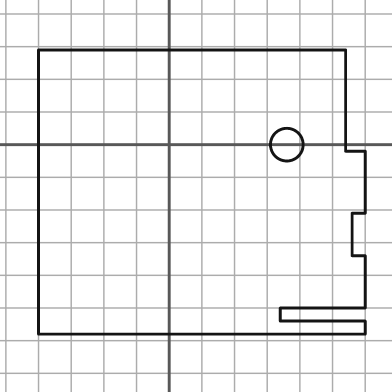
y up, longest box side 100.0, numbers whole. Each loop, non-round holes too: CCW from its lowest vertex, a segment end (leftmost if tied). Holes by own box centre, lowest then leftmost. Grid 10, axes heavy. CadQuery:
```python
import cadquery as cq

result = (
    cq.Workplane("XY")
    .moveTo(-40.0, -58.0)
    .lineTo(60.0, -58.0)
    .lineTo(60.0, -54.0)
    .lineTo(34.0, -54.0)
    .lineTo(34.0, -50.0)
    .lineTo(60.0, -50.0)
    .lineTo(60.0, -34.0)
    .lineTo(56.0, -34.0)
    .lineTo(56.0, -21.0)
    .lineTo(60.0, -21.0)
    .lineTo(60.0, -2.0)
    .lineTo(54.0, -2.0)
    .lineTo(54.0, 29.0)
    .lineTo(-40.0, 29.0)
    .close()
    .moveTo(36.0, 0.0)
    .circle(5.0)
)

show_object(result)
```